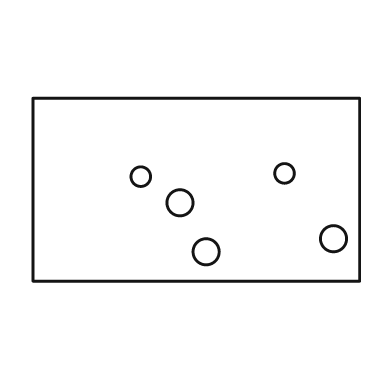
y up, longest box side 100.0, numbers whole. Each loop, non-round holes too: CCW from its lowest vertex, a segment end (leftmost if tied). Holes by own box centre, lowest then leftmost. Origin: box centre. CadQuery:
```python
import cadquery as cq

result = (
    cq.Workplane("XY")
    .moveTo(-50.0, -28.0)
    .lineTo(50.0, -28.0)
    .lineTo(50.0, 28.0)
    .lineTo(-50.0, 28.0)
    .close()
    .moveTo(3.0, -19.0)
    .circle(4.0)
    .moveTo(42.0, -15.0)
    .circle(4.0)
    .moveTo(-5.0, -4.0)
    .circle(4.0)
    .moveTo(-17.0, 4.0)
    .circle(3.0)
    .moveTo(27.0, 5.0)
    .circle(3.0)
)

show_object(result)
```